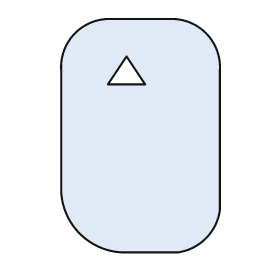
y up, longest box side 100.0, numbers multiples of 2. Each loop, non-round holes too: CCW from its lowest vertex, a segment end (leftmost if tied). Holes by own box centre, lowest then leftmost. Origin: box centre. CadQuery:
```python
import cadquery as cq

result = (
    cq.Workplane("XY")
    .moveTo(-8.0, -50.0)
    .lineTo(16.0, -50.0)
    .threePointArc((28.0, -44.0), (34.0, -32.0))
    .lineTo(34.0, 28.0)
    .threePointArc((28.0, 44.0), (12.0, 50.0))
    .lineTo(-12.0, 50.0)
    .threePointArc((-28.0, 44.0), (-34.0, 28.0))
    .lineTo(-34.0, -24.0)
    .threePointArc((-26.0, -42.0), (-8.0, -50.0))
    .close()
    .moveTo(-14.0, 22.0)
    .lineTo(2.0, 22.0)
    .lineTo(-6.0, 34.0)
    .close()
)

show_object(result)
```